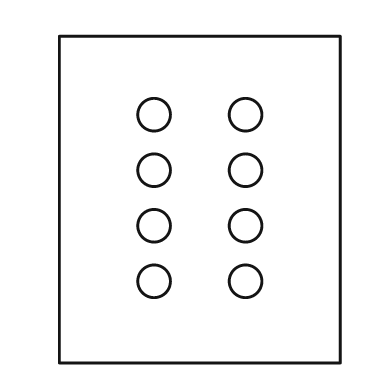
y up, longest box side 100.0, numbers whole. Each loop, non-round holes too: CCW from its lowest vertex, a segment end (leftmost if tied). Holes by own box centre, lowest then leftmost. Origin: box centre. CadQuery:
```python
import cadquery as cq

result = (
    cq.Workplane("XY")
    .moveTo(-43.0, -50.0)
    .lineTo(43.0, -50.0)
    .lineTo(43.0, 50.0)
    .lineTo(-43.0, 50.0)
    .close()
    .moveTo(-14.0, -25.0)
    .circle(5.0)
    .moveTo(14.0, -25.0)
    .circle(5.0)
    .moveTo(-14.0, -8.0)
    .circle(5.0)
    .moveTo(14.0, -8.0)
    .circle(5.0)
    .moveTo(-14.0, 9.0)
    .circle(5.0)
    .moveTo(14.0, 9.0)
    .circle(5.0)
    .moveTo(-14.0, 26.0)
    .circle(5.0)
    .moveTo(14.0, 26.0)
    .circle(5.0)
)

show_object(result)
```